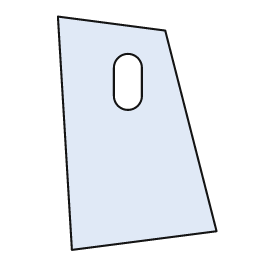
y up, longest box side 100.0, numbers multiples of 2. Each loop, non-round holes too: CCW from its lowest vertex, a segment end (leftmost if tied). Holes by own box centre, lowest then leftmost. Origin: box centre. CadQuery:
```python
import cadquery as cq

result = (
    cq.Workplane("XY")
    .moveTo(-28.0, -50.0)
    .lineTo(34.0, -42.0)
    .lineTo(12.0, 44.0)
    .lineTo(-34.0, 50.0)
    .close()
    .moveTo(-10.0, 16.0)
    .threePointArc((-4.0, 10.0), (2.0, 16.0))
    .lineTo(2.0, 28.0)
    .threePointArc((-4.0, 34.0), (-10.0, 28.0))
    .close()
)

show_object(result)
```